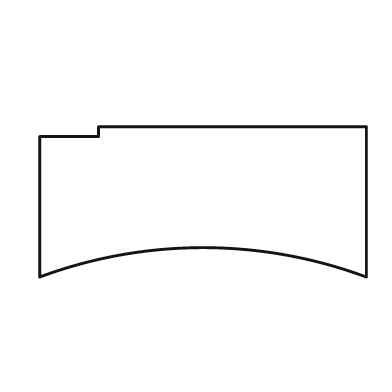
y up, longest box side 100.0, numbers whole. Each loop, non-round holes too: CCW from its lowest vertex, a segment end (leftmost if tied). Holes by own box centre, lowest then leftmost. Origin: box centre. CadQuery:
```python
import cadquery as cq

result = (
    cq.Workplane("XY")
    .moveTo(-50.0, -23.0)
    .threePointArc((0.0, -14.0), (50.0, -23.0))
    .lineTo(50.0, 23.0)
    .lineTo(-32.0, 23.0)
    .lineTo(-32.0, 20.0)
    .lineTo(-50.0, 20.0)
    .close()
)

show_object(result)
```